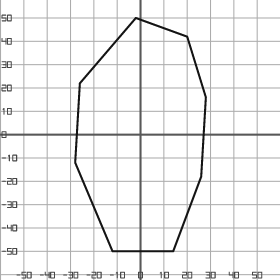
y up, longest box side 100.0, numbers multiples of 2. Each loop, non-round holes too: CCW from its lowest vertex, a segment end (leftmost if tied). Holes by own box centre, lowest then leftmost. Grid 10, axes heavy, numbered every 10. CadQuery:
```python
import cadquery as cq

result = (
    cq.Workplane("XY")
    .moveTo(-12.0, -50.0)
    .lineTo(14.0, -50.0)
    .lineTo(26.0, -18.0)
    .lineTo(28.0, 16.0)
    .lineTo(20.0, 42.0)
    .lineTo(-2.0, 50.0)
    .lineTo(-26.0, 22.0)
    .lineTo(-28.0, -12.0)
    .close()
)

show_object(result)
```